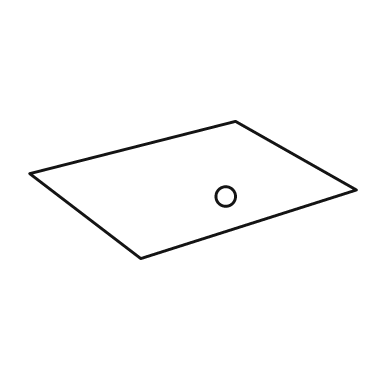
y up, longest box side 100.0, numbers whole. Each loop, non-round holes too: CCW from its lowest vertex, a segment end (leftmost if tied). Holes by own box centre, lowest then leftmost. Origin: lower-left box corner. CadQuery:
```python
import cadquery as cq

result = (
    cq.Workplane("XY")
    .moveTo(34.0, 0.0)
    .lineTo(100.0, 21.0)
    .lineTo(63.0, 42.0)
    .lineTo(0.0, 26.0)
    .close()
    .moveTo(60.0, 19.0)
    .circle(3.0)
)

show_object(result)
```